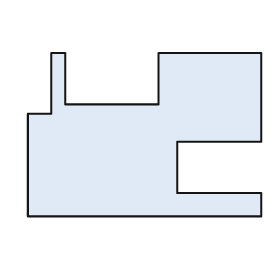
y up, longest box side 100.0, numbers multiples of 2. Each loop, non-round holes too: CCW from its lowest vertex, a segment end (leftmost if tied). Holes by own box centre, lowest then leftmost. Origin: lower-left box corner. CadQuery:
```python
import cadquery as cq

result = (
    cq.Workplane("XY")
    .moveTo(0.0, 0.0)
    .lineTo(100.0, 0.0)
    .lineTo(100.0, 10.0)
    .lineTo(64.0, 10.0)
    .lineTo(64.0, 32.0)
    .lineTo(100.0, 32.0)
    .lineTo(100.0, 70.0)
    .lineTo(56.0, 70.0)
    .lineTo(56.0, 48.0)
    .lineTo(16.0, 48.0)
    .lineTo(16.0, 70.0)
    .lineTo(10.0, 70.0)
    .lineTo(10.0, 44.0)
    .lineTo(0.0, 44.0)
    .close()
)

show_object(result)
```